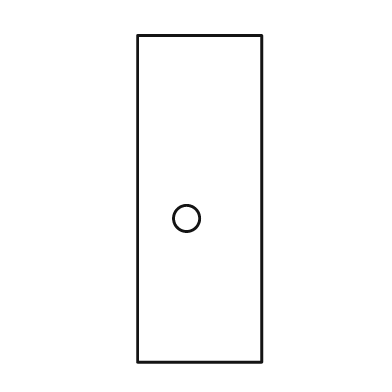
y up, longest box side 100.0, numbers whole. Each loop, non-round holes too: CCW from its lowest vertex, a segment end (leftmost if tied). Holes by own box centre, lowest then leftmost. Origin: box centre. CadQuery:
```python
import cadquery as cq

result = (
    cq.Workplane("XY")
    .moveTo(-19.0, -50.0)
    .lineTo(19.0, -50.0)
    .lineTo(19.0, 50.0)
    .lineTo(-19.0, 50.0)
    .close()
    .moveTo(-4.0, -6.0)
    .circle(4.0)
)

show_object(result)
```